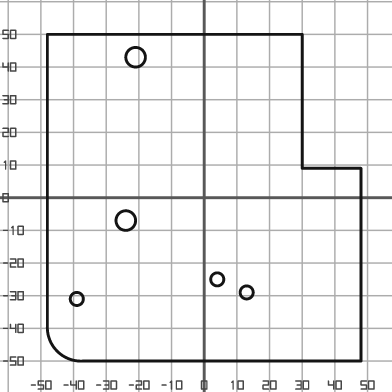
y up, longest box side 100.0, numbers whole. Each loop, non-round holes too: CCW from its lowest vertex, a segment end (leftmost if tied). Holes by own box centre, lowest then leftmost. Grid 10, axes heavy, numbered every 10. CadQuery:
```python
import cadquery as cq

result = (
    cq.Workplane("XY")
    .moveTo(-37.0, -50.0)
    .lineTo(48.0, -50.0)
    .lineTo(48.0, 9.0)
    .lineTo(30.0, 9.0)
    .lineTo(30.0, 50.0)
    .lineTo(-48.0, 50.0)
    .lineTo(-48.0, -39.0)
    .threePointArc((-45.0, -47.0), (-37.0, -50.0))
    .close()
    .moveTo(-39.0, -31.0)
    .circle(2.0)
    .moveTo(13.0, -29.0)
    .circle(2.0)
    .moveTo(4.0, -25.0)
    .circle(2.0)
    .moveTo(-24.0, -7.0)
    .circle(3.0)
    .moveTo(-21.0, 43.0)
    .circle(3.0)
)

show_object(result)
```